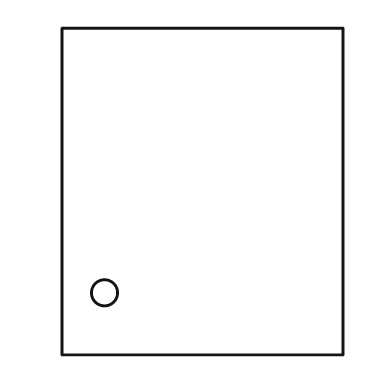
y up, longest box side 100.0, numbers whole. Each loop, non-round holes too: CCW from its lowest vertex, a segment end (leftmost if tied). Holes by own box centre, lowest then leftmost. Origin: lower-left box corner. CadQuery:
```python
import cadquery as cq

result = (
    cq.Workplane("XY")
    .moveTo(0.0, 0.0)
    .lineTo(86.0, 0.0)
    .lineTo(86.0, 100.0)
    .lineTo(0.0, 100.0)
    .close()
    .moveTo(13.0, 19.0)
    .circle(4.0)
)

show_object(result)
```